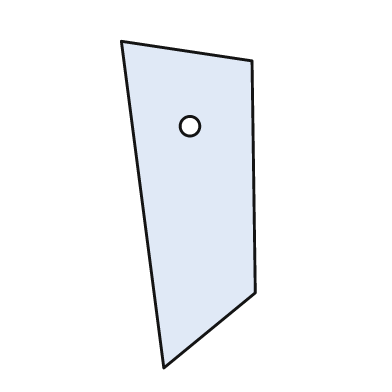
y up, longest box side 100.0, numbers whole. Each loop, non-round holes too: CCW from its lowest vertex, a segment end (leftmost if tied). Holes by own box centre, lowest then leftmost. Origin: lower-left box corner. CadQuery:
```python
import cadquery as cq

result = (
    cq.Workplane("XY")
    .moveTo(13.0, 0.0)
    .lineTo(41.0, 23.0)
    .lineTo(40.0, 94.0)
    .lineTo(0.0, 100.0)
    .close()
    .moveTo(21.0, 74.0)
    .circle(3.0)
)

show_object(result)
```